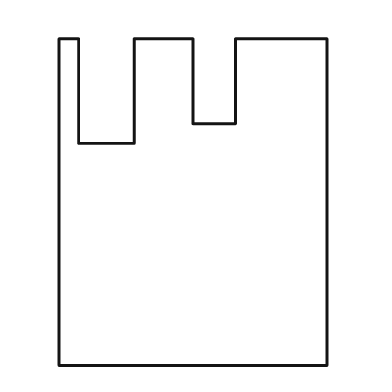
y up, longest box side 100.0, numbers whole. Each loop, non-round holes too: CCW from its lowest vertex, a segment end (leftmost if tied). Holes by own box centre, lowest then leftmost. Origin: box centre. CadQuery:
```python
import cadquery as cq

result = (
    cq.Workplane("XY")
    .moveTo(-41.0, -50.0)
    .lineTo(41.0, -50.0)
    .lineTo(41.0, 50.0)
    .lineTo(13.0, 50.0)
    .lineTo(13.0, 24.0)
    .lineTo(0.0, 24.0)
    .lineTo(0.0, 50.0)
    .lineTo(-18.0, 50.0)
    .lineTo(-18.0, 18.0)
    .lineTo(-35.0, 18.0)
    .lineTo(-35.0, 50.0)
    .lineTo(-41.0, 50.0)
    .close()
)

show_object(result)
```